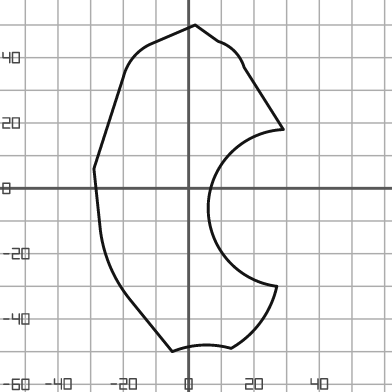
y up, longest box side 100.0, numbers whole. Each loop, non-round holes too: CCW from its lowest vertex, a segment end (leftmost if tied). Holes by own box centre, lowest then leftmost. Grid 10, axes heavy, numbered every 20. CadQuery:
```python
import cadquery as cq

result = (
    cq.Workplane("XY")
    .moveTo(-5.0, -50.0)
    .threePointArc((4.0, -48.0), (13.0, -49.0))
    .threePointArc((22.0, -41.0), (27.0, -30.0))
    .threePointArc((6.0, -5.0), (29.0, 18.0))
    .lineTo(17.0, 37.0)
    .threePointArc((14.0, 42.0), (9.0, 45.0))
    .lineTo(2.0, 50.0)
    .lineTo(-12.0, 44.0)
    .threePointArc((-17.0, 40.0), (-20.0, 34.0))
    .lineTo(-29.0, 6.0)
    .lineTo(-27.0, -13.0)
    .threePointArc((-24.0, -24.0), (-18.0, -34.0))
    .close()
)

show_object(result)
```